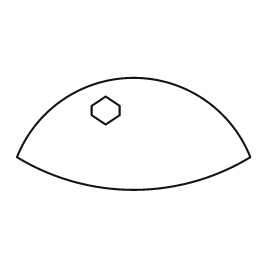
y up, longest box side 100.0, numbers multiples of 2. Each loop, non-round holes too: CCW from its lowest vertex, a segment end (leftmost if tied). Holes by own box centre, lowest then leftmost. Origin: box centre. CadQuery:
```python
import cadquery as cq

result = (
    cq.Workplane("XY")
    .moveTo(-50.0, -10.0)
    .threePointArc((0.0, -24.0), (50.0, -10.0))
    .threePointArc((0.0, 24.0), (-50.0, -10.0))
    .close()
    .moveTo(-12.0, 4.0)
    .lineTo(-6.0, 8.0)
    .lineTo(-6.0, 12.0)
    .lineTo(-12.0, 16.0)
    .lineTo(-18.0, 12.0)
    .lineTo(-18.0, 8.0)
    .close()
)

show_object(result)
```